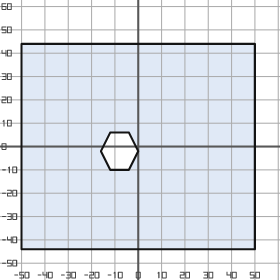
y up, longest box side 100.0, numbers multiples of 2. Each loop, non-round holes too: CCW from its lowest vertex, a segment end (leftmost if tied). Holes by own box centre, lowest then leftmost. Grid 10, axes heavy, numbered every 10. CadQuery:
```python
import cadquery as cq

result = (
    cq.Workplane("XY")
    .moveTo(-50.0, -44.0)
    .lineTo(50.0, -44.0)
    .lineTo(50.0, 44.0)
    .lineTo(-50.0, 44.0)
    .close()
    .moveTo(-12.0, -10.0)
    .lineTo(-4.0, -10.0)
    .lineTo(0.0, -2.0)
    .lineTo(-4.0, 6.0)
    .lineTo(-12.0, 6.0)
    .lineTo(-16.0, -2.0)
    .close()
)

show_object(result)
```